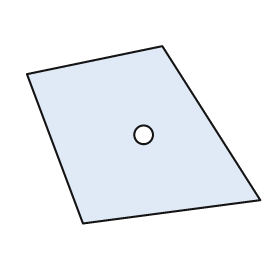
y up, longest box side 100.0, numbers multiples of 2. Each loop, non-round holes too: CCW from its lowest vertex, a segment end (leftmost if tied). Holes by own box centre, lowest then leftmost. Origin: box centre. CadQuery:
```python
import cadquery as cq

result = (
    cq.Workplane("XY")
    .moveTo(-26.0, -38.0)
    .lineTo(50.0, -28.0)
    .lineTo(8.0, 38.0)
    .lineTo(-50.0, 26.0)
    .close()
    .moveTo(0.0, 0.0)
    .circle(4.0)
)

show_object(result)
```